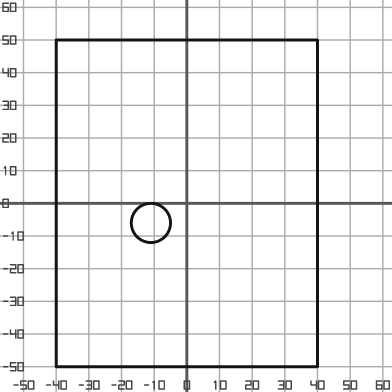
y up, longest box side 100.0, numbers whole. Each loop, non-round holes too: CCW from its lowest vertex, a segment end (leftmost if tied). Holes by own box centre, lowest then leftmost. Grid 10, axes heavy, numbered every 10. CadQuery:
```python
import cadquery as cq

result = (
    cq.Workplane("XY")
    .moveTo(-40.0, -50.0)
    .lineTo(40.0, -50.0)
    .lineTo(40.0, 50.0)
    .lineTo(-40.0, 50.0)
    .close()
    .moveTo(-11.0, -6.0)
    .circle(6.0)
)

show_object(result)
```